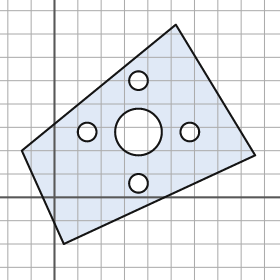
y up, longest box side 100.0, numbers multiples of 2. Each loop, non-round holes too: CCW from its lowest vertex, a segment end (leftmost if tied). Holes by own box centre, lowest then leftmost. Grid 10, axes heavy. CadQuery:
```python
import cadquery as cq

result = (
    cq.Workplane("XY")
    .moveTo(4.0, -20.0)
    .lineTo(86.0, 18.0)
    .lineTo(52.0, 74.0)
    .lineTo(-14.0, 20.0)
    .close()
    .moveTo(36.0, 6.0)
    .circle(4.0)
    .moveTo(14.0, 28.0)
    .circle(4.0)
    .moveTo(36.0, 28.0)
    .circle(10.0)
    .moveTo(58.0, 28.0)
    .circle(4.0)
    .moveTo(36.0, 50.0)
    .circle(4.0)
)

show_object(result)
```